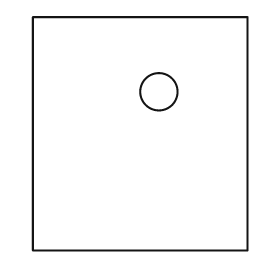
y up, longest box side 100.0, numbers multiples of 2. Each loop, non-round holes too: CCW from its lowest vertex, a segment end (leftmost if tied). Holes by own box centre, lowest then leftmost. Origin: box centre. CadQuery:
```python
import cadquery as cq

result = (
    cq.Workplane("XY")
    .moveTo(-46.0, -50.0)
    .lineTo(46.0, -50.0)
    .lineTo(46.0, 50.0)
    .lineTo(-46.0, 50.0)
    .close()
    .moveTo(8.0, 18.0)
    .circle(8.0)
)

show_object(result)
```